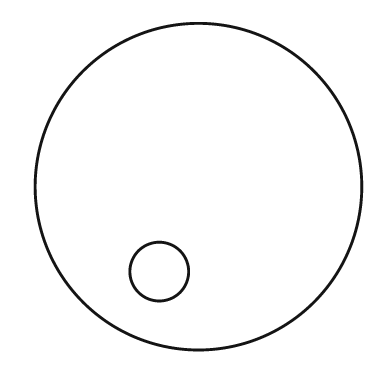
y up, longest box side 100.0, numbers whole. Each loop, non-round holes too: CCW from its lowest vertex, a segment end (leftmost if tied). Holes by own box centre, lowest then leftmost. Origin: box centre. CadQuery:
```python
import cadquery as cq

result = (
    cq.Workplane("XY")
    .moveTo(0.0, 0.0)
    .circle(50.0)
    .moveTo(-12.0, -26.0)
    .circle(9.0)
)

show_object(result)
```